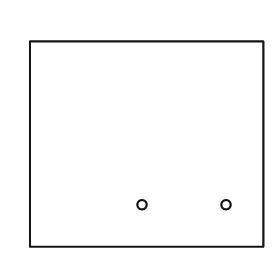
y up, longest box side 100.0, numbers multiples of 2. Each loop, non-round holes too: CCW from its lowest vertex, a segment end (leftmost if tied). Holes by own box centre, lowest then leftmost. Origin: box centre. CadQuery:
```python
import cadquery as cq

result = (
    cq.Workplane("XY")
    .moveTo(-50.0, -44.0)
    .lineTo(50.0, -44.0)
    .lineTo(50.0, 44.0)
    .lineTo(-50.0, 44.0)
    .close()
    .moveTo(-2.0, -26.0)
    .circle(2.0)
    .moveTo(34.0, -26.0)
    .circle(2.0)
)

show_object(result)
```